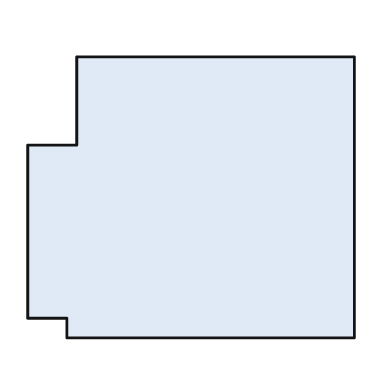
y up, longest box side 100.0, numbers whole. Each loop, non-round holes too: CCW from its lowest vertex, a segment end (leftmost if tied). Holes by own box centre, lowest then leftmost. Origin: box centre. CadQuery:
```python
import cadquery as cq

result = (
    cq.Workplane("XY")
    .moveTo(-38.0, -43.0)
    .lineTo(50.0, -43.0)
    .lineTo(50.0, 43.0)
    .lineTo(-35.0, 43.0)
    .lineTo(-35.0, 16.0)
    .lineTo(-50.0, 16.0)
    .lineTo(-50.0, -37.0)
    .lineTo(-38.0, -37.0)
    .close()
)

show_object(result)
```